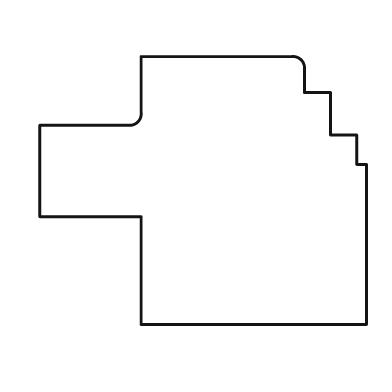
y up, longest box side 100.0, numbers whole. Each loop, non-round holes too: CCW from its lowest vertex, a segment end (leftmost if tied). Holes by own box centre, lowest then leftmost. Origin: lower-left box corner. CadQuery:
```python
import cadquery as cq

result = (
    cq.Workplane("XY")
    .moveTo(31.0, 0.0)
    .lineTo(100.0, 0.0)
    .lineTo(100.0, 49.0)
    .lineTo(97.0, 49.0)
    .lineTo(97.0, 58.0)
    .lineTo(89.0, 58.0)
    .lineTo(89.0, 71.0)
    .lineTo(81.0, 71.0)
    .lineTo(81.0, 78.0)
    .threePointArc((80.0, 81.0), (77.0, 82.0))
    .lineTo(31.0, 82.0)
    .lineTo(31.0, 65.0)
    .threePointArc((30.0, 62.0), (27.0, 61.0))
    .lineTo(0.0, 61.0)
    .lineTo(0.0, 33.0)
    .lineTo(31.0, 33.0)
    .close()
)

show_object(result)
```